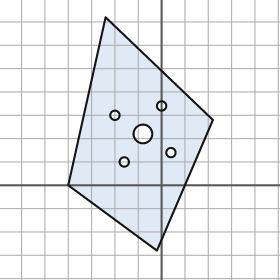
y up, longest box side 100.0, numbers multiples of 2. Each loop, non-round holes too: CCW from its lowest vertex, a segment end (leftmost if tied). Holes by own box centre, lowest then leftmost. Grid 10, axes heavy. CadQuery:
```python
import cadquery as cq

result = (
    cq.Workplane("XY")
    .moveTo(-2.0, -28.0)
    .lineTo(22.0, 28.0)
    .lineTo(-24.0, 72.0)
    .lineTo(-40.0, 0.0)
    .close()
    .moveTo(-16.0, 10.0)
    .circle(2.0)
    .moveTo(4.0, 14.0)
    .circle(2.0)
    .moveTo(-8.0, 22.0)
    .circle(4.0)
    .moveTo(-20.0, 30.0)
    .circle(2.0)
    .moveTo(0.0, 34.0)
    .circle(2.0)
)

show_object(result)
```